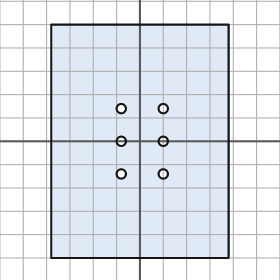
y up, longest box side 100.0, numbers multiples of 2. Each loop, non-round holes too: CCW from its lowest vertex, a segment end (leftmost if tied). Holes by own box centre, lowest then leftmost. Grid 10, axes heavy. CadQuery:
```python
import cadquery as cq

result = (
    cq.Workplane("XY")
    .moveTo(-38.0, -50.0)
    .lineTo(38.0, -50.0)
    .lineTo(38.0, 50.0)
    .lineTo(-38.0, 50.0)
    .close()
    .moveTo(-8.0, -14.0)
    .circle(2.0)
    .moveTo(10.0, -14.0)
    .circle(2.0)
    .moveTo(-8.0, 0.0)
    .circle(2.0)
    .moveTo(10.0, 0.0)
    .circle(2.0)
    .moveTo(-8.0, 14.0)
    .circle(2.0)
    .moveTo(10.0, 14.0)
    .circle(2.0)
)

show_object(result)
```